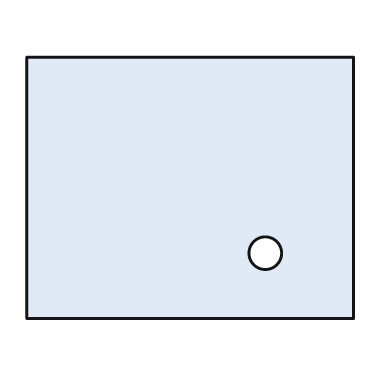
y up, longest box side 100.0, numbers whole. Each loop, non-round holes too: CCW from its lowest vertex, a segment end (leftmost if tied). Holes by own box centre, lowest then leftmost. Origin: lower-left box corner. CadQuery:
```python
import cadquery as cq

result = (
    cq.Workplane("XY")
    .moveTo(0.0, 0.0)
    .lineTo(100.0, 0.0)
    .lineTo(100.0, 80.0)
    .lineTo(0.0, 80.0)
    .close()
    .moveTo(73.0, 20.0)
    .circle(5.0)
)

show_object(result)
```